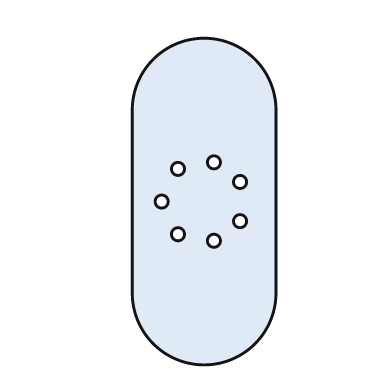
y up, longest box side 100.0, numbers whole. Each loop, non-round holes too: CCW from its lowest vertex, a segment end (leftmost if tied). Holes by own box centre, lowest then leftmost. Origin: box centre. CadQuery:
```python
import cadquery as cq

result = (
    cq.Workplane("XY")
    .moveTo(-22.0, -28.0)
    .threePointArc((0.0, -50.0), (22.0, -28.0))
    .lineTo(22.0, 28.0)
    .threePointArc((0.0, 50.0), (-22.0, 28.0))
    .close()
    .moveTo(3.0, -12.0)
    .circle(2.0)
    .moveTo(-8.0, -10.0)
    .circle(2.0)
    .moveTo(11.0, -6.0)
    .circle(2.0)
    .moveTo(-13.0, 0.0)
    .circle(2.0)
    .moveTo(11.0, 6.0)
    .circle(2.0)
    .moveTo(-8.0, 10.0)
    .circle(2.0)
    .moveTo(3.0, 12.0)
    .circle(2.0)
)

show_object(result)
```